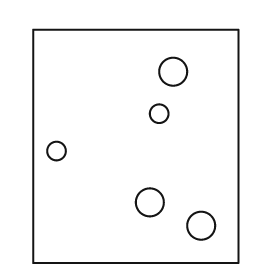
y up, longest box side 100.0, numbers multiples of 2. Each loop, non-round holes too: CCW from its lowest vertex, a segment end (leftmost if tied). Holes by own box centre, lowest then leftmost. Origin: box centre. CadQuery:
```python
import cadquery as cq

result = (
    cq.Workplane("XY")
    .moveTo(-44.0, -50.0)
    .lineTo(44.0, -50.0)
    .lineTo(44.0, 50.0)
    .lineTo(-44.0, 50.0)
    .close()
    .moveTo(28.0, -34.0)
    .circle(6.0)
    .moveTo(6.0, -24.0)
    .circle(6.0)
    .moveTo(-34.0, -2.0)
    .circle(4.0)
    .moveTo(10.0, 14.0)
    .circle(4.0)
    .moveTo(16.0, 32.0)
    .circle(6.0)
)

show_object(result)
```